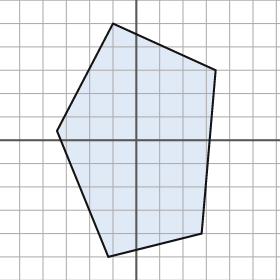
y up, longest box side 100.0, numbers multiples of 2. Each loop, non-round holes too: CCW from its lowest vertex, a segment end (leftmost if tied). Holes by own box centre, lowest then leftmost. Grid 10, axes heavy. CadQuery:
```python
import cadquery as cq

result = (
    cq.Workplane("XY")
    .moveTo(-12.0, -50.0)
    .lineTo(28.0, -40.0)
    .lineTo(34.0, 30.0)
    .lineTo(-10.0, 50.0)
    .lineTo(-34.0, 4.0)
    .close()
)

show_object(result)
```